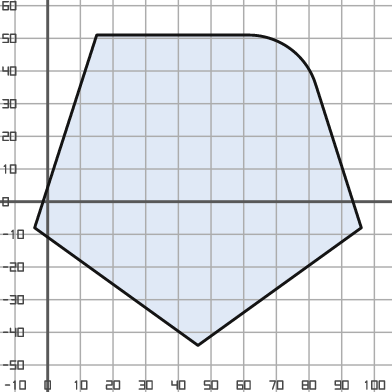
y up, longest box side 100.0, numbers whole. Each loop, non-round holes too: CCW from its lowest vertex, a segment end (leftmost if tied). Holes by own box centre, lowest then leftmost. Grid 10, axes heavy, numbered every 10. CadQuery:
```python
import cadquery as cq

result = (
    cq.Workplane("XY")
    .moveTo(46.0, -44.0)
    .lineTo(96.0, -8.0)
    .lineTo(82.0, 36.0)
    .threePointArc((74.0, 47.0), (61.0, 51.0))
    .lineTo(15.0, 51.0)
    .lineTo(-4.0, -8.0)
    .close()
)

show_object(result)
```